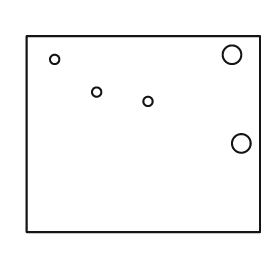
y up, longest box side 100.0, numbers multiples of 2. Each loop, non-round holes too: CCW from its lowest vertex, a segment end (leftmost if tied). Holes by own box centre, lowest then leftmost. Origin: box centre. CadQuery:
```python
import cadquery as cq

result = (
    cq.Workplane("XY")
    .moveTo(-50.0, -42.0)
    .lineTo(50.0, -42.0)
    .lineTo(50.0, 42.0)
    .lineTo(-50.0, 42.0)
    .close()
    .moveTo(42.0, -4.0)
    .circle(4.0)
    .moveTo(2.0, 14.0)
    .circle(2.0)
    .moveTo(-20.0, 18.0)
    .circle(2.0)
    .moveTo(-38.0, 32.0)
    .circle(2.0)
    .moveTo(38.0, 34.0)
    .circle(4.0)
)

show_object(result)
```